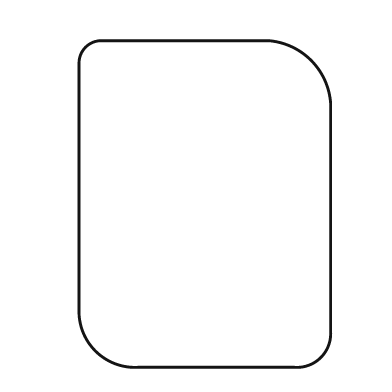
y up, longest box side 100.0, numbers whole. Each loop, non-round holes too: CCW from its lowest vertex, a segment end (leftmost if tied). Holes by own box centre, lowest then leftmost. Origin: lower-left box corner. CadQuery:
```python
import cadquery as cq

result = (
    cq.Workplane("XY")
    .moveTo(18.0, 0.0)
    .lineTo(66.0, 0.0)
    .threePointArc((74.0, 3.0), (77.0, 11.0))
    .lineTo(77.0, 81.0)
    .threePointArc((71.0, 94.0), (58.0, 100.0))
    .lineTo(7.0, 100.0)
    .threePointArc((2.0, 98.0), (0.0, 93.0))
    .lineTo(0.0, 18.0)
    .threePointArc((5.0, 5.0), (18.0, 0.0))
    .close()
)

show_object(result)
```